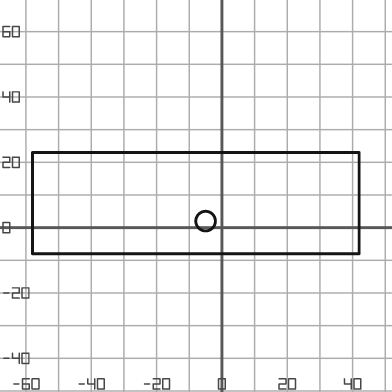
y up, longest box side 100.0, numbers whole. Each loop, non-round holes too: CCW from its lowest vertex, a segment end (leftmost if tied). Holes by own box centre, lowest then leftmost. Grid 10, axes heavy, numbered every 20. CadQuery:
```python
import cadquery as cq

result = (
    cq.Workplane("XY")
    .moveTo(-58.0, -8.0)
    .lineTo(42.0, -8.0)
    .lineTo(42.0, 23.0)
    .lineTo(-58.0, 23.0)
    .close()
    .moveTo(-5.0, 2.0)
    .circle(3.0)
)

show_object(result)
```